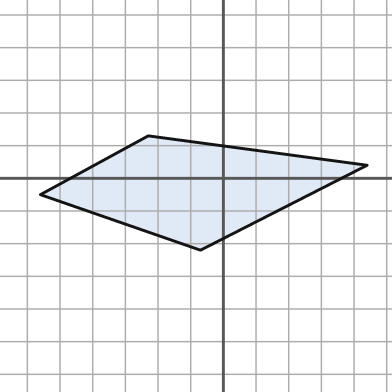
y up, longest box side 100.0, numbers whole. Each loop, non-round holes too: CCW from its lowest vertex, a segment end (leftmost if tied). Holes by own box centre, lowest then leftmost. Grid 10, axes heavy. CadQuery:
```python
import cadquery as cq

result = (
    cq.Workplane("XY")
    .moveTo(-7.0, -22.0)
    .lineTo(44.0, 4.0)
    .lineTo(-23.0, 13.0)
    .lineTo(-56.0, -5.0)
    .close()
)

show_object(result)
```